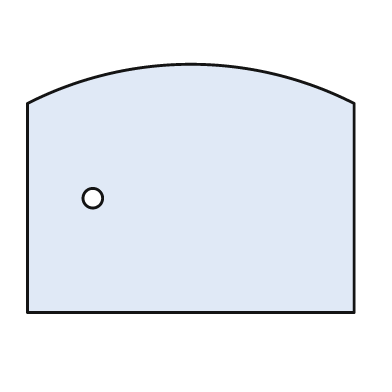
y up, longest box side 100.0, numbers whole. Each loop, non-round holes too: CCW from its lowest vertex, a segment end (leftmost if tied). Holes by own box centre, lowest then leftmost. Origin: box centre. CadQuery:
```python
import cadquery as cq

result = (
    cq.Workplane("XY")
    .moveTo(-50.0, -38.0)
    .lineTo(50.0, -38.0)
    .lineTo(50.0, 26.0)
    .threePointArc((0.0, 38.0), (-50.0, 26.0))
    .close()
    .moveTo(-30.0, -3.0)
    .circle(3.0)
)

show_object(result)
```